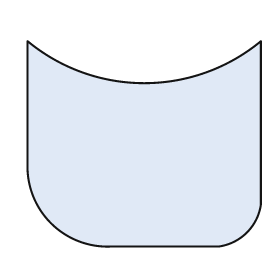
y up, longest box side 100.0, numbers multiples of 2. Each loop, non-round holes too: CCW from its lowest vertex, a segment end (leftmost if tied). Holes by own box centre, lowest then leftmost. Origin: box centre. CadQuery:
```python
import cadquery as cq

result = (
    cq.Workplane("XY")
    .moveTo(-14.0, -44.0)
    .lineTo(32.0, -44.0)
    .threePointArc((44.0, -38.0), (50.0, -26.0))
    .lineTo(50.0, 44.0)
    .threePointArc((0.0, 26.0), (-50.0, 44.0))
    .lineTo(-50.0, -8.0)
    .threePointArc((-40.0, -34.0), (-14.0, -44.0))
    .close()
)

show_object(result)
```